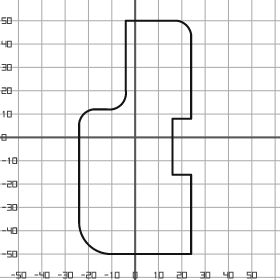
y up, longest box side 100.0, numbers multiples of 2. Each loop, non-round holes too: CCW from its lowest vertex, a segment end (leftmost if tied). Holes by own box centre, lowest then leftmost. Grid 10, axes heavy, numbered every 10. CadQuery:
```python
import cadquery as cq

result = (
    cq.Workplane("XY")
    .moveTo(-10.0, -50.0)
    .lineTo(24.0, -50.0)
    .lineTo(24.0, -16.0)
    .lineTo(16.0, -16.0)
    .lineTo(16.0, 8.0)
    .lineTo(24.0, 8.0)
    .lineTo(24.0, 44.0)
    .threePointArc((22.0, 48.0), (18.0, 50.0))
    .lineTo(-4.0, 50.0)
    .lineTo(-4.0, 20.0)
    .threePointArc((-6.0, 14.0), (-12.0, 12.0))
    .lineTo(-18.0, 12.0)
    .threePointArc((-22.0, 10.0), (-24.0, 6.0))
    .lineTo(-24.0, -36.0)
    .threePointArc((-20.0, -46.0), (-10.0, -50.0))
    .close()
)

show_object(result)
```